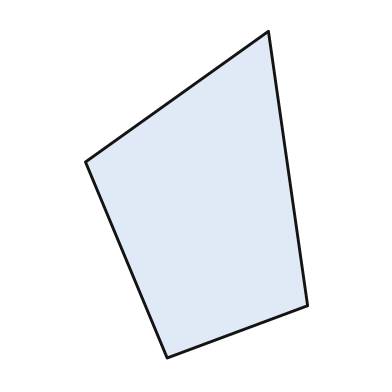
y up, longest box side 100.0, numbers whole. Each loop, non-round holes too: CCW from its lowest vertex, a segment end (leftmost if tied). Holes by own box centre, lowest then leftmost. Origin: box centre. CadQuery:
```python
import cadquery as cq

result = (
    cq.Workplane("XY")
    .moveTo(-9.0, -50.0)
    .lineTo(34.0, -34.0)
    .lineTo(22.0, 50.0)
    .lineTo(-34.0, 10.0)
    .close()
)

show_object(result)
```